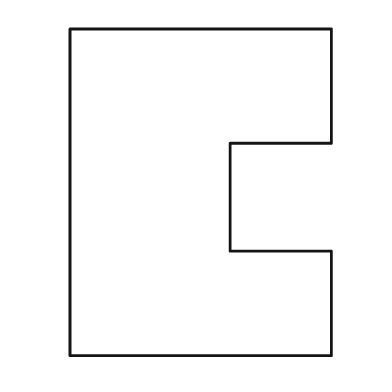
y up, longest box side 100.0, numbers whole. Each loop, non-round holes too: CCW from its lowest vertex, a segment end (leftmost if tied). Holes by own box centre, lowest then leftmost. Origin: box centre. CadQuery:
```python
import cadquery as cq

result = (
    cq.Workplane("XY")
    .moveTo(-40.0, -50.0)
    .lineTo(40.0, -50.0)
    .lineTo(40.0, -18.0)
    .lineTo(9.0, -18.0)
    .lineTo(9.0, 15.0)
    .lineTo(40.0, 15.0)
    .lineTo(40.0, 50.0)
    .lineTo(-40.0, 50.0)
    .close()
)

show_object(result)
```